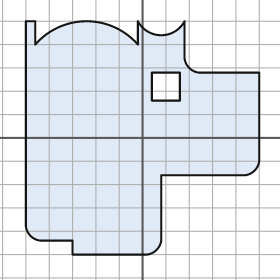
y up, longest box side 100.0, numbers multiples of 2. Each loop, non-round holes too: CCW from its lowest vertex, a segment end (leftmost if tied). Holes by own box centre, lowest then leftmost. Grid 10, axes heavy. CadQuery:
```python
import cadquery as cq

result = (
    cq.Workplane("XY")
    .moveTo(-30.0, -50.0)
    .lineTo(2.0, -50.0)
    .threePointArc((6.0, -48.0), (8.0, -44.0))
    .lineTo(8.0, -16.0)
    .lineTo(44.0, -16.0)
    .threePointArc((48.0, -14.0), (50.0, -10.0))
    .lineTo(50.0, 28.0)
    .lineTo(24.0, 28.0)
    .threePointArc((20.0, 30.0), (18.0, 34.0))
    .lineTo(18.0, 50.0)
    .threePointArc((8.0, 44.0), (-2.0, 50.0))
    .lineTo(-2.0, 40.0)
    .threePointArc((-24.0, 50.0), (-46.0, 40.0))
    .lineTo(-46.0, 50.0)
    .lineTo(-50.0, 50.0)
    .lineTo(-50.0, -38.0)
    .threePointArc((-48.0, -42.0), (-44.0, -44.0))
    .lineTo(-30.0, -44.0)
    .close()
    .moveTo(4.0, 16.0)
    .lineTo(16.0, 16.0)
    .lineTo(16.0, 28.0)
    .lineTo(4.0, 28.0)
    .close()
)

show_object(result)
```